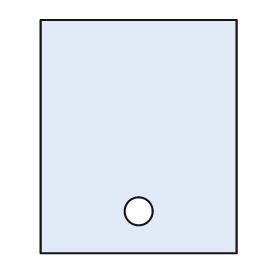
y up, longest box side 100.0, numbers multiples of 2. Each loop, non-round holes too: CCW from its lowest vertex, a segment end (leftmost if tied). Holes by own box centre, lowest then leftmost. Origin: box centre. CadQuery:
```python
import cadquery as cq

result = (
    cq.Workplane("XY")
    .moveTo(-42.0, -50.0)
    .lineTo(42.0, -50.0)
    .lineTo(42.0, 50.0)
    .lineTo(-42.0, 50.0)
    .close()
    .moveTo(0.0, -32.0)
    .circle(6.0)
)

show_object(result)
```